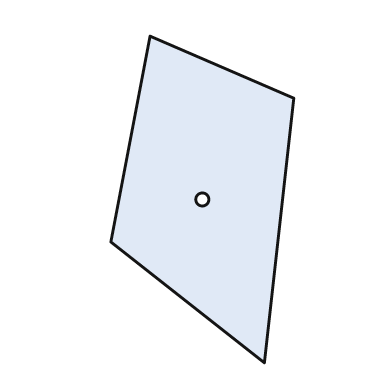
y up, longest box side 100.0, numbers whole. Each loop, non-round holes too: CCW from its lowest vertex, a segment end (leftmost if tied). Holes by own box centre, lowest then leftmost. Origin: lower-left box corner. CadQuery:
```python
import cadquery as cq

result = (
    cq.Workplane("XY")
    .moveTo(47.0, 0.0)
    .lineTo(56.0, 81.0)
    .lineTo(12.0, 100.0)
    .lineTo(0.0, 37.0)
    .close()
    .moveTo(28.0, 50.0)
    .circle(2.0)
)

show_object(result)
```